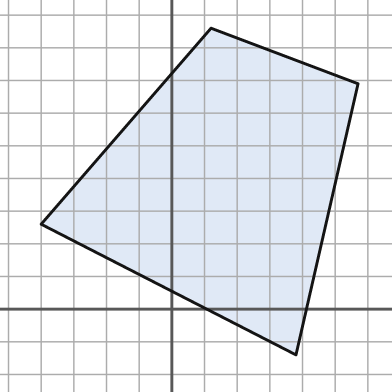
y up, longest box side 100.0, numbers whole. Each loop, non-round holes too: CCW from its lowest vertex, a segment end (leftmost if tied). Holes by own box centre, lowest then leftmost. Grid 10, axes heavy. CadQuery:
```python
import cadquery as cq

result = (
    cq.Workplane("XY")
    .moveTo(38.0, -14.0)
    .lineTo(57.0, 69.0)
    .lineTo(12.0, 86.0)
    .lineTo(-40.0, 26.0)
    .close()
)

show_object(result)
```